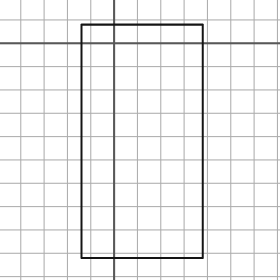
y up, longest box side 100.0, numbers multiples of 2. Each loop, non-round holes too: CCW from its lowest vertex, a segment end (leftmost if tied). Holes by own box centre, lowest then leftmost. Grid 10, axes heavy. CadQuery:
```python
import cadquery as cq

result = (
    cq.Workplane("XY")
    .moveTo(-14.0, -92.0)
    .lineTo(38.0, -92.0)
    .lineTo(38.0, 8.0)
    .lineTo(-14.0, 8.0)
    .close()
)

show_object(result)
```